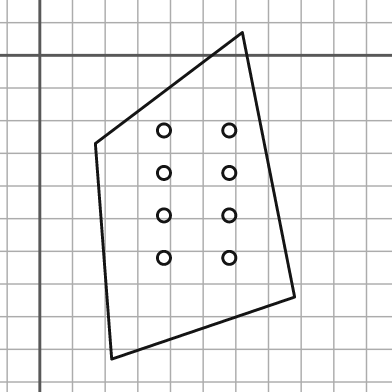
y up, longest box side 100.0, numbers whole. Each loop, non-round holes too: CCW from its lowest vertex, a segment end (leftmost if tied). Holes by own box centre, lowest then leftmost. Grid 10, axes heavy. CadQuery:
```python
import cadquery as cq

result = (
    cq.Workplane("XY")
    .moveTo(22.0, -93.0)
    .lineTo(78.0, -74.0)
    .lineTo(62.0, 7.0)
    .lineTo(17.0, -27.0)
    .close()
    .moveTo(38.0, -62.0)
    .circle(2.0)
    .moveTo(58.0, -62.0)
    .circle(2.0)
    .moveTo(38.0, -49.0)
    .circle(2.0)
    .moveTo(58.0, -49.0)
    .circle(2.0)
    .moveTo(38.0, -36.0)
    .circle(2.0)
    .moveTo(58.0, -36.0)
    .circle(2.0)
    .moveTo(38.0, -23.0)
    .circle(2.0)
    .moveTo(58.0, -23.0)
    .circle(2.0)
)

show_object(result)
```